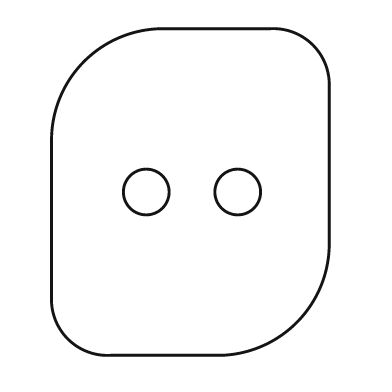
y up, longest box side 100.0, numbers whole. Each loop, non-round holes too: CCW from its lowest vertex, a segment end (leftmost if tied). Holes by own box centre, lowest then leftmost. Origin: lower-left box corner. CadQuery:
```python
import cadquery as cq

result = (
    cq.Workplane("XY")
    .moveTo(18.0, 0.0)
    .lineTo(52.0, 0.0)
    .threePointArc((75.0, 10.0), (85.0, 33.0))
    .lineTo(85.0, 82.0)
    .threePointArc((80.0, 95.0), (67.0, 100.0))
    .lineTo(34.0, 100.0)
    .threePointArc((10.0, 90.0), (0.0, 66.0))
    .lineTo(0.0, 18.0)
    .threePointArc((5.0, 5.0), (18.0, 0.0))
    .close()
    .moveTo(29.0, 50.0)
    .circle(7.0)
    .moveTo(57.0, 50.0)
    .circle(7.0)
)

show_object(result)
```